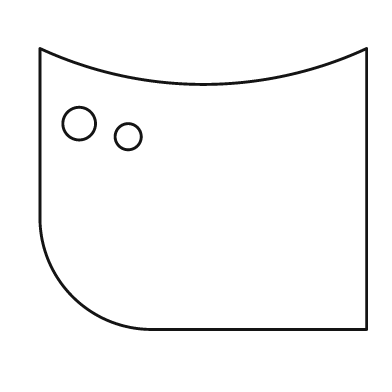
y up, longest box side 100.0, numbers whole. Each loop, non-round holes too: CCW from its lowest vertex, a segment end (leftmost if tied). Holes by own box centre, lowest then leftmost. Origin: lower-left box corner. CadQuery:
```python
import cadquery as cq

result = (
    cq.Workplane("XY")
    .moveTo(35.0, 0.0)
    .lineTo(100.0, 0.0)
    .lineTo(100.0, 86.0)
    .threePointArc((50.0, 75.0), (0.0, 86.0))
    .lineTo(0.0, 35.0)
    .threePointArc((10.0, 10.0), (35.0, 0.0))
    .close()
    .moveTo(27.0, 59.0)
    .circle(4.0)
    .moveTo(12.0, 63.0)
    .circle(5.0)
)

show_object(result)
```